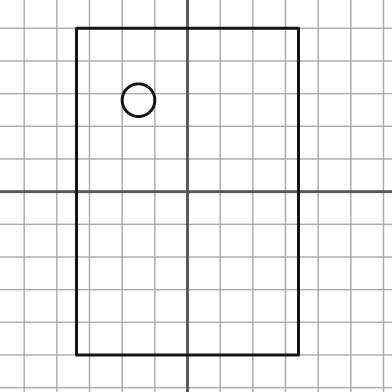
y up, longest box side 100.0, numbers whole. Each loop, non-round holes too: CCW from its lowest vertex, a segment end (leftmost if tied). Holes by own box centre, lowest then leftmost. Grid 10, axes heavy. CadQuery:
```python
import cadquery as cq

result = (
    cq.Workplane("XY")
    .moveTo(-34.0, -50.0)
    .lineTo(34.0, -50.0)
    .lineTo(34.0, 50.0)
    .lineTo(-34.0, 50.0)
    .close()
    .moveTo(-15.0, 28.0)
    .circle(5.0)
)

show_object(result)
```